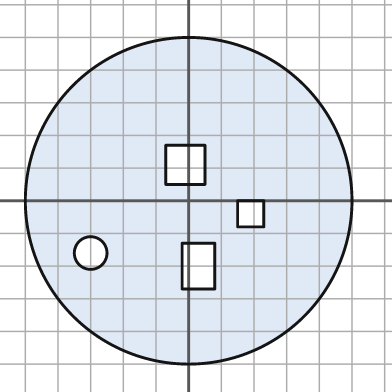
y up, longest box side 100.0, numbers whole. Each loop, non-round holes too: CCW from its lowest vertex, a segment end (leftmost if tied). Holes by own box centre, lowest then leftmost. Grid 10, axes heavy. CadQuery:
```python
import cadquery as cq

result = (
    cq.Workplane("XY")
    .moveTo(0.0, 0.0)
    .circle(50.0)
    .moveTo(-2.0, -27.0)
    .lineTo(8.0, -27.0)
    .lineTo(8.0, -13.0)
    .lineTo(-2.0, -13.0)
    .close()
    .moveTo(-30.0, -16.0)
    .circle(5.0)
    .moveTo(15.0, -8.0)
    .lineTo(23.0, -8.0)
    .lineTo(23.0, 0.0)
    .lineTo(15.0, 0.0)
    .close()
    .moveTo(-7.0, 5.0)
    .lineTo(5.0, 5.0)
    .lineTo(5.0, 17.0)
    .lineTo(-7.0, 17.0)
    .close()
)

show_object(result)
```